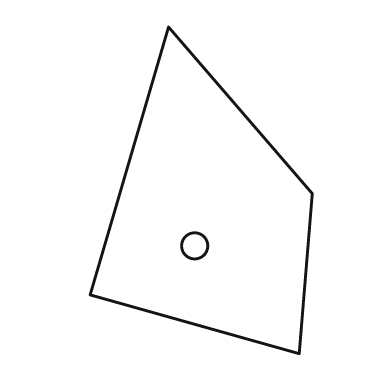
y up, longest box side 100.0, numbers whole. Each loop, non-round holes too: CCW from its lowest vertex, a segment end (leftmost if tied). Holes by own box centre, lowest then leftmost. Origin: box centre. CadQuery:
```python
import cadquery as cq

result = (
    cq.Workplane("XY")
    .moveTo(30.0, -50.0)
    .lineTo(34.0, -1.0)
    .lineTo(-10.0, 50.0)
    .lineTo(-34.0, -32.0)
    .close()
    .moveTo(-2.0, -17.0)
    .circle(4.0)
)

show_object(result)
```